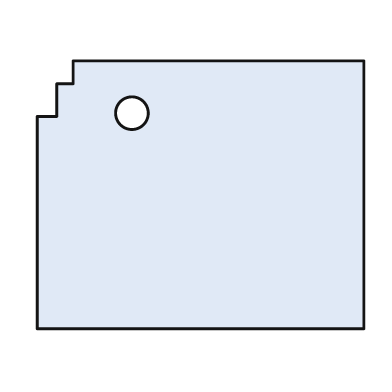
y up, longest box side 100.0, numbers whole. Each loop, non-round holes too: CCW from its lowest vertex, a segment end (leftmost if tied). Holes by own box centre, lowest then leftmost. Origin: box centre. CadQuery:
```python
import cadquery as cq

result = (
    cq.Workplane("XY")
    .moveTo(-50.0, -41.0)
    .lineTo(50.0, -41.0)
    .lineTo(50.0, 41.0)
    .lineTo(-39.0, 41.0)
    .lineTo(-39.0, 34.0)
    .lineTo(-44.0, 34.0)
    .lineTo(-44.0, 24.0)
    .lineTo(-50.0, 24.0)
    .close()
    .moveTo(-21.0, 25.0)
    .circle(5.0)
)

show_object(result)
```